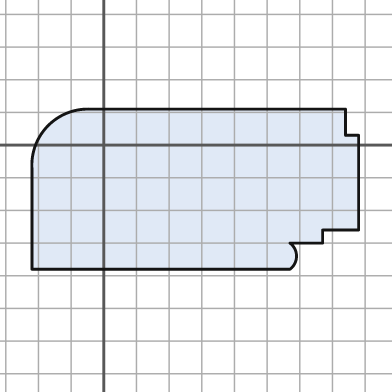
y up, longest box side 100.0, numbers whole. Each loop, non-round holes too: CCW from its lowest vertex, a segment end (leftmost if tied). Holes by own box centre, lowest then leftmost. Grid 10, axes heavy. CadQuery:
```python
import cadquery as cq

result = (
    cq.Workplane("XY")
    .moveTo(-22.0, -38.0)
    .lineTo(57.0, -38.0)
    .threePointArc((59.0, -34.0), (57.0, -30.0))
    .lineTo(67.0, -30.0)
    .lineTo(67.0, -26.0)
    .lineTo(78.0, -26.0)
    .lineTo(78.0, 3.0)
    .lineTo(74.0, 3.0)
    .lineTo(74.0, 11.0)
    .lineTo(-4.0, 11.0)
    .threePointArc((-17.0, 6.0), (-22.0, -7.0))
    .close()
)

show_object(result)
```